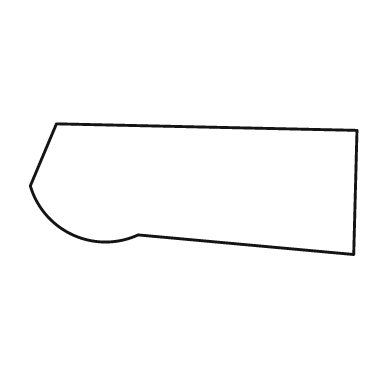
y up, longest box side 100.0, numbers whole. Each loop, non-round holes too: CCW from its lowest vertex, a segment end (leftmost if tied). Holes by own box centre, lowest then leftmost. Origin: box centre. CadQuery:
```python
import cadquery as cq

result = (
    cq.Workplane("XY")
    .moveTo(49.0, -20.0)
    .lineTo(50.0, 18.0)
    .lineTo(-42.0, 20.0)
    .lineTo(-50.0, 1.0)
    .threePointArc((-37.0, -14.0), (-17.0, -14.0))
    .close()
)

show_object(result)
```